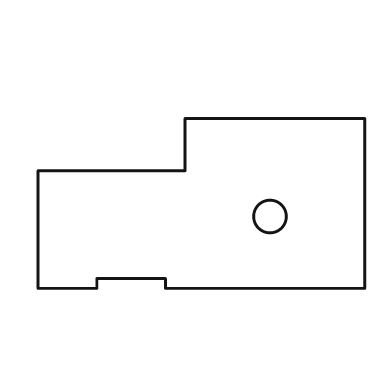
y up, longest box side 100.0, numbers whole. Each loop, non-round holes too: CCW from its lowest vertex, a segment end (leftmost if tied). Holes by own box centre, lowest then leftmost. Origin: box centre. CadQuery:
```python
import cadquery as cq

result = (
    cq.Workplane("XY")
    .moveTo(-50.0, -26.0)
    .lineTo(-32.0, -26.0)
    .lineTo(-32.0, -23.0)
    .lineTo(-11.0, -23.0)
    .lineTo(-11.0, -26.0)
    .lineTo(50.0, -26.0)
    .lineTo(50.0, 26.0)
    .lineTo(-5.0, 26.0)
    .lineTo(-5.0, 10.0)
    .lineTo(-50.0, 10.0)
    .close()
    .moveTo(21.0, -4.0)
    .circle(5.0)
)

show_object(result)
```